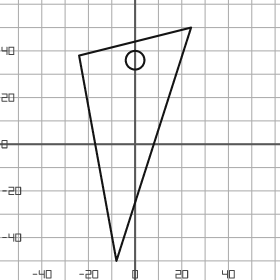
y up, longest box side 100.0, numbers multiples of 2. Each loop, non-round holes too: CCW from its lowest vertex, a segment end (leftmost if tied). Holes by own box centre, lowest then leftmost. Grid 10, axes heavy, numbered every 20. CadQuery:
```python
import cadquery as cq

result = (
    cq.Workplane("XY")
    .moveTo(-8.0, -50.0)
    .lineTo(24.0, 50.0)
    .lineTo(-24.0, 38.0)
    .close()
    .moveTo(0.0, 36.0)
    .circle(4.0)
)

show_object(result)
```